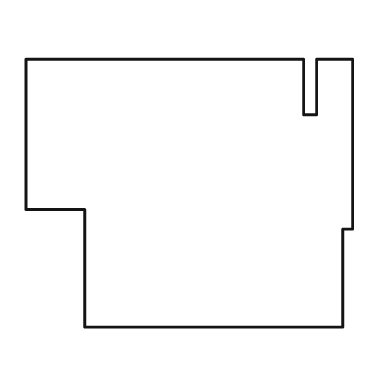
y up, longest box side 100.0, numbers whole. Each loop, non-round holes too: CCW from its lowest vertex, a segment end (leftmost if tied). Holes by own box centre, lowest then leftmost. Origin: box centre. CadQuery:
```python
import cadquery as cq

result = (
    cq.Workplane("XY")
    .moveTo(-32.0, -41.0)
    .lineTo(47.0, -41.0)
    .lineTo(47.0, -11.0)
    .lineTo(50.0, -11.0)
    .lineTo(50.0, 41.0)
    .lineTo(39.0, 41.0)
    .lineTo(39.0, 24.0)
    .lineTo(35.0, 24.0)
    .lineTo(35.0, 41.0)
    .lineTo(-50.0, 41.0)
    .lineTo(-50.0, -5.0)
    .lineTo(-32.0, -5.0)
    .close()
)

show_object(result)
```